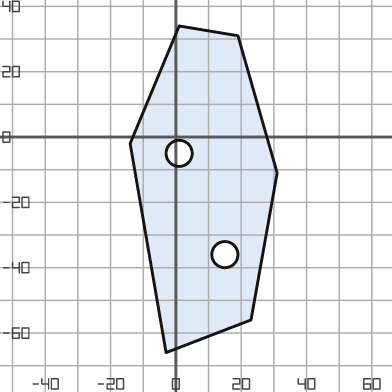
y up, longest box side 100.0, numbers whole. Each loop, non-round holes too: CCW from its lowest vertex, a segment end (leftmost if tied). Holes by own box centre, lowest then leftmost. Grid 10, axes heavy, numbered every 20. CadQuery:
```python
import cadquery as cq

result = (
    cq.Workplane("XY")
    .moveTo(-3.0, -66.0)
    .lineTo(23.0, -56.0)
    .lineTo(31.0, -11.0)
    .lineTo(19.0, 31.0)
    .lineTo(1.0, 34.0)
    .lineTo(-14.0, -2.0)
    .close()
    .moveTo(15.0, -36.0)
    .circle(4.0)
    .moveTo(1.0, -5.0)
    .circle(4.0)
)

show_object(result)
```